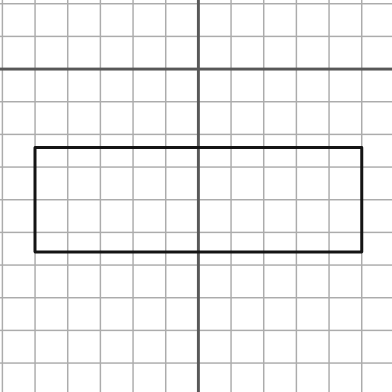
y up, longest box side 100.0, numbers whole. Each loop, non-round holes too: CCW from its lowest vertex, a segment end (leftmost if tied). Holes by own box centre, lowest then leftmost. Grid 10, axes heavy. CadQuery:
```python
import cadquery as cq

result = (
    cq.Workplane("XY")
    .moveTo(-50.0, -56.0)
    .lineTo(50.0, -56.0)
    .lineTo(50.0, -24.0)
    .lineTo(-50.0, -24.0)
    .close()
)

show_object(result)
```